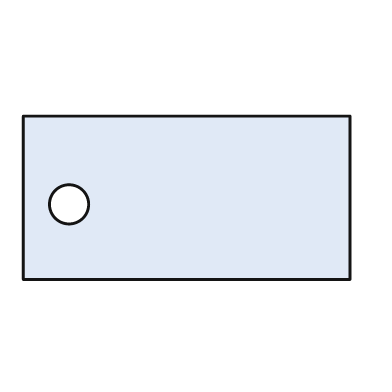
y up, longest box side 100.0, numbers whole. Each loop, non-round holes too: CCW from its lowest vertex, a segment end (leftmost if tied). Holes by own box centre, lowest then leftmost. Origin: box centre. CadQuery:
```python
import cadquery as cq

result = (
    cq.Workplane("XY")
    .moveTo(-50.0, -25.0)
    .lineTo(50.0, -25.0)
    .lineTo(50.0, 25.0)
    .lineTo(-50.0, 25.0)
    .close()
    .moveTo(-36.0, -2.0)
    .circle(6.0)
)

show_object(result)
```